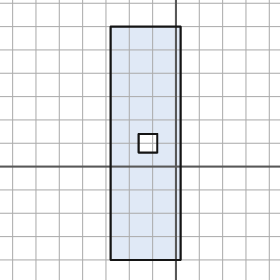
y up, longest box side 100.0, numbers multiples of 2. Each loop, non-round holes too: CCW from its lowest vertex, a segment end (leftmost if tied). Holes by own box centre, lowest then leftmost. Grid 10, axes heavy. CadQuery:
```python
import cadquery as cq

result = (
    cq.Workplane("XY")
    .moveTo(-28.0, -40.0)
    .lineTo(2.0, -40.0)
    .lineTo(2.0, 60.0)
    .lineTo(-28.0, 60.0)
    .close()
    .moveTo(-16.0, 6.0)
    .lineTo(-8.0, 6.0)
    .lineTo(-8.0, 14.0)
    .lineTo(-16.0, 14.0)
    .close()
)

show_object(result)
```